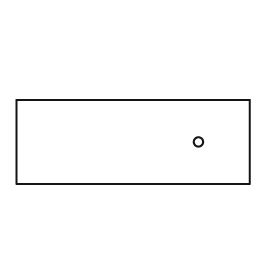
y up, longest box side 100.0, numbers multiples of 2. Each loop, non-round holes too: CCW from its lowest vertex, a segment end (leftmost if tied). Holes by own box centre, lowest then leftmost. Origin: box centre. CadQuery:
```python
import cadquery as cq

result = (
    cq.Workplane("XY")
    .moveTo(-50.0, -18.0)
    .lineTo(50.0, -18.0)
    .lineTo(50.0, 18.0)
    .lineTo(-50.0, 18.0)
    .close()
    .moveTo(28.0, 0.0)
    .circle(2.0)
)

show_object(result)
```